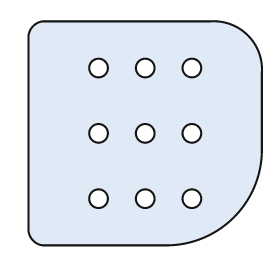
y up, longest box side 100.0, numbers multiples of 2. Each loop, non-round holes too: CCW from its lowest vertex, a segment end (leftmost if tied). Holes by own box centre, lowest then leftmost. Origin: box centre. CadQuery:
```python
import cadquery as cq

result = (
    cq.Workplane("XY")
    .moveTo(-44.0, -48.0)
    .lineTo(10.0, -48.0)
    .threePointArc((38.0, -36.0), (50.0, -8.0))
    .lineTo(50.0, 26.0)
    .threePointArc((44.0, 42.0), (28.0, 48.0))
    .lineTo(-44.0, 48.0)
    .threePointArc((-48.0, 46.0), (-50.0, 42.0))
    .lineTo(-50.0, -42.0)
    .threePointArc((-48.0, -46.0), (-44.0, -48.0))
    .close()
    .moveTo(-20.0, -28.0)
    .circle(4.0)
    .moveTo(0.0, -28.0)
    .circle(4.0)
    .moveTo(20.0, -28.0)
    .circle(4.0)
    .moveTo(-20.0, 0.0)
    .circle(4.0)
    .moveTo(0.0, 0.0)
    .circle(4.0)
    .moveTo(20.0, 0.0)
    .circle(4.0)
    .moveTo(-20.0, 28.0)
    .circle(4.0)
    .moveTo(0.0, 28.0)
    .circle(4.0)
    .moveTo(20.0, 28.0)
    .circle(4.0)
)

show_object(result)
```